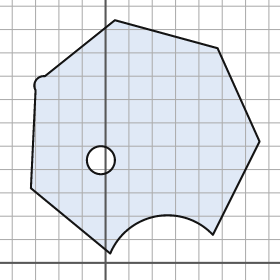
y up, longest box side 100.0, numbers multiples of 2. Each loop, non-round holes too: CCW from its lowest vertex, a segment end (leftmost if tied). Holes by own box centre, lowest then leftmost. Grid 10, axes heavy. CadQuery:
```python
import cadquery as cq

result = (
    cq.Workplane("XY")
    .moveTo(2.0, 4.0)
    .threePointArc((22.0, 20.0), (46.0, 12.0))
    .lineTo(66.0, 52.0)
    .lineTo(48.0, 92.0)
    .lineTo(4.0, 104.0)
    .lineTo(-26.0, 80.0)
    .threePointArc((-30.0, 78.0), (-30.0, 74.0))
    .lineTo(-32.0, 32.0)
    .close()
    .moveTo(-2.0, 44.0)
    .circle(6.0)
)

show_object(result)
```